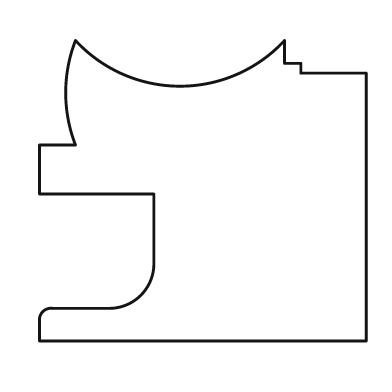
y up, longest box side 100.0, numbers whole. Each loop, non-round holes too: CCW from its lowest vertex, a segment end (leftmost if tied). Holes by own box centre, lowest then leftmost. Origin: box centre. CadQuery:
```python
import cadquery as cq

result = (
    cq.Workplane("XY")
    .moveTo(-50.0, -46.0)
    .lineTo(50.0, -46.0)
    .lineTo(50.0, 36.0)
    .lineTo(30.0, 36.0)
    .lineTo(30.0, 39.0)
    .lineTo(25.0, 39.0)
    .lineTo(25.0, 46.0)
    .threePointArc((-7.0, 32.0), (-39.0, 46.0))
    .threePointArc((-42.0, 30.0), (-39.0, 14.0))
    .lineTo(-50.0, 14.0)
    .lineTo(-50.0, -1.0)
    .lineTo(-15.0, -1.0)
    .lineTo(-15.0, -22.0)
    .threePointArc((-19.0, -32.0), (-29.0, -36.0))
    .lineTo(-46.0, -36.0)
    .threePointArc((-49.0, -37.0), (-50.0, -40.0))
    .close()
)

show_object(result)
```